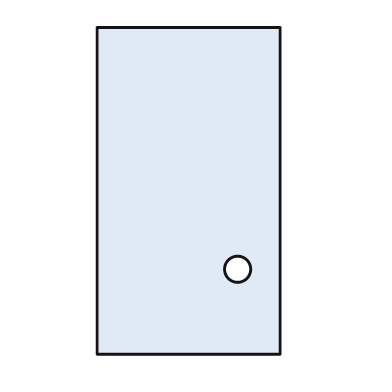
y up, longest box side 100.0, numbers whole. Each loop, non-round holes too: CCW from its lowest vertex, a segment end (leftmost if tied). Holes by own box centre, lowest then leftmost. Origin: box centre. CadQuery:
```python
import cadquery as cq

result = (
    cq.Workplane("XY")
    .moveTo(-28.0, -50.0)
    .lineTo(28.0, -50.0)
    .lineTo(28.0, 50.0)
    .lineTo(-28.0, 50.0)
    .close()
    .moveTo(15.0, -24.0)
    .circle(4.0)
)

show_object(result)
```